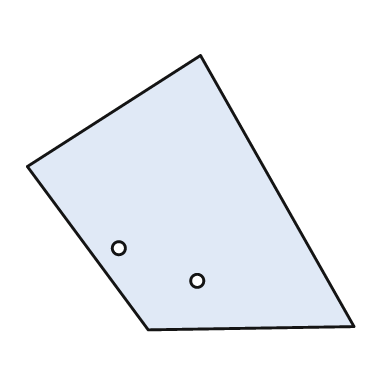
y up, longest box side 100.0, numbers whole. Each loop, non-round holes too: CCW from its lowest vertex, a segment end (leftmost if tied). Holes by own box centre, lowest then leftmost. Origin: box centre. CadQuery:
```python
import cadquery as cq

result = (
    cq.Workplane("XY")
    .moveTo(-13.0, -42.0)
    .lineTo(50.0, -41.0)
    .lineTo(3.0, 42.0)
    .lineTo(-50.0, 8.0)
    .close()
    .moveTo(2.0, -27.0)
    .circle(2.0)
    .moveTo(-22.0, -17.0)
    .circle(2.0)
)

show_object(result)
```